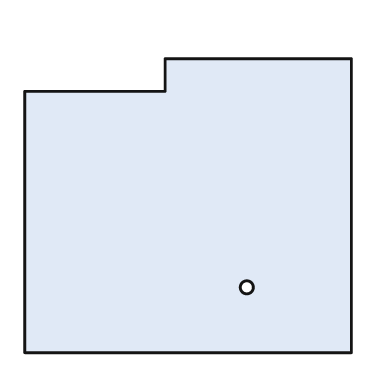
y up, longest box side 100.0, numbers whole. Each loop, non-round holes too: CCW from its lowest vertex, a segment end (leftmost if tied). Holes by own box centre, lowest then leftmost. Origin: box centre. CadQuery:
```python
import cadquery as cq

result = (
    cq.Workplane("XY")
    .moveTo(-50.0, -45.0)
    .lineTo(50.0, -45.0)
    .lineTo(50.0, 45.0)
    .lineTo(-7.0, 45.0)
    .lineTo(-7.0, 35.0)
    .lineTo(-50.0, 35.0)
    .close()
    .moveTo(18.0, -25.0)
    .circle(2.0)
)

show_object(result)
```